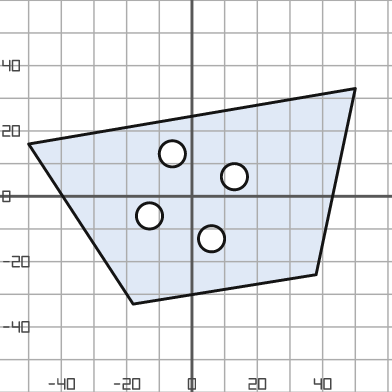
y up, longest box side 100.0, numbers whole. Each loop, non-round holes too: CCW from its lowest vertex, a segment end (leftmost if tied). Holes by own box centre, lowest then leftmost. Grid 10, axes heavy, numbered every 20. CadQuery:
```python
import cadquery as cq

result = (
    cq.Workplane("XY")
    .moveTo(-18.0, -33.0)
    .lineTo(38.0, -24.0)
    .lineTo(50.0, 33.0)
    .lineTo(-50.0, 16.0)
    .close()
    .moveTo(6.0, -13.0)
    .circle(4.0)
    .moveTo(-13.0, -6.0)
    .circle(4.0)
    .moveTo(13.0, 6.0)
    .circle(4.0)
    .moveTo(-6.0, 13.0)
    .circle(4.0)
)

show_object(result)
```